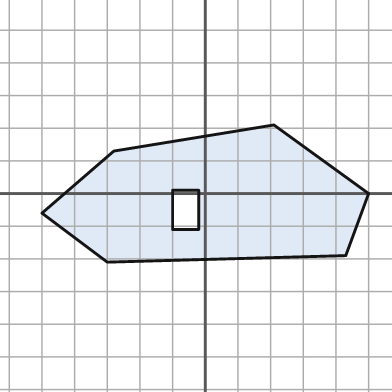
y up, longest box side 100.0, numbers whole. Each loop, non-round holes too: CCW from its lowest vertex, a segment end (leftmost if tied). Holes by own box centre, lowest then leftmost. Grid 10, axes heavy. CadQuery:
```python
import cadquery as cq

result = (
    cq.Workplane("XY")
    .moveTo(-30.0, -21.0)
    .lineTo(43.0, -19.0)
    .lineTo(50.0, 0.0)
    .lineTo(21.0, 21.0)
    .lineTo(-28.0, 13.0)
    .lineTo(-50.0, -6.0)
    .close()
    .moveTo(-10.0, -11.0)
    .lineTo(-2.0, -11.0)
    .lineTo(-2.0, 1.0)
    .lineTo(-10.0, 1.0)
    .close()
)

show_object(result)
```